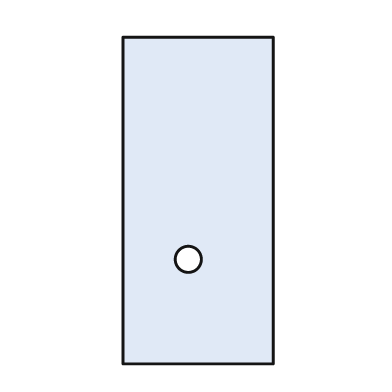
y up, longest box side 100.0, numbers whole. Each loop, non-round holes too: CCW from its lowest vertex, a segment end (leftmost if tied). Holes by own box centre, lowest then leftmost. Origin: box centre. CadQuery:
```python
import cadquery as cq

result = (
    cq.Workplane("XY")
    .moveTo(-23.0, -50.0)
    .lineTo(23.0, -50.0)
    .lineTo(23.0, 50.0)
    .lineTo(-23.0, 50.0)
    .close()
    .moveTo(-3.0, -18.0)
    .circle(4.0)
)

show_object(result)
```